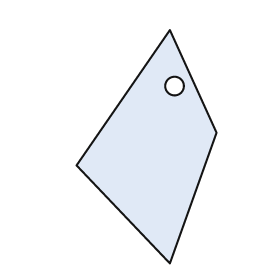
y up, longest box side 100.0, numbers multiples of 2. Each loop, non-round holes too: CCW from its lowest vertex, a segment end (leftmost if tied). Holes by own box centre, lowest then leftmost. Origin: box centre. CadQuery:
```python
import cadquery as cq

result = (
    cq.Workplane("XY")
    .moveTo(10.0, -50.0)
    .lineTo(30.0, 6.0)
    .lineTo(10.0, 50.0)
    .lineTo(-30.0, -8.0)
    .close()
    .moveTo(12.0, 26.0)
    .circle(4.0)
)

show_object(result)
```